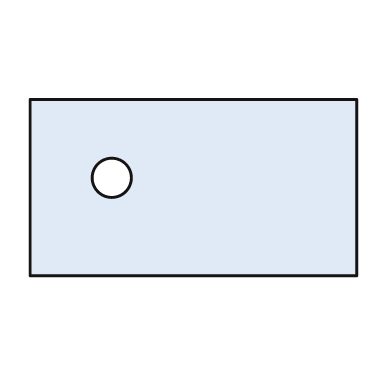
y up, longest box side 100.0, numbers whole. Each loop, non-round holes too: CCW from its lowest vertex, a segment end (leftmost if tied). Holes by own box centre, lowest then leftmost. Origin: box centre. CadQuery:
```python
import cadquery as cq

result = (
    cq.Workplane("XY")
    .moveTo(-50.0, -27.0)
    .lineTo(50.0, -27.0)
    .lineTo(50.0, 27.0)
    .lineTo(-50.0, 27.0)
    .close()
    .moveTo(-25.0, 3.0)
    .circle(6.0)
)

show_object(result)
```